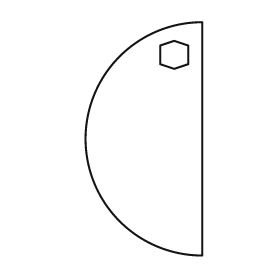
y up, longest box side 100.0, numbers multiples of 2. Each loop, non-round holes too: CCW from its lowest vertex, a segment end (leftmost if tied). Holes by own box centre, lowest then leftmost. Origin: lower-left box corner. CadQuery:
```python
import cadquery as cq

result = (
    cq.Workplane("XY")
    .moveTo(50.0, 0.0)
    .lineTo(50.0, 100.0)
    .threePointArc((0.0, 50.0), (50.0, 0.0))
    .close()
    .moveTo(38.0, 80.0)
    .lineTo(44.0, 82.0)
    .lineTo(44.0, 90.0)
    .lineTo(38.0, 92.0)
    .lineTo(32.0, 90.0)
    .lineTo(32.0, 82.0)
    .close()
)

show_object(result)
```